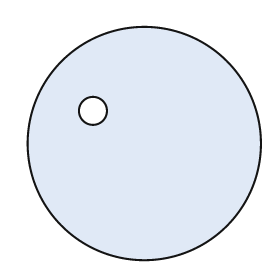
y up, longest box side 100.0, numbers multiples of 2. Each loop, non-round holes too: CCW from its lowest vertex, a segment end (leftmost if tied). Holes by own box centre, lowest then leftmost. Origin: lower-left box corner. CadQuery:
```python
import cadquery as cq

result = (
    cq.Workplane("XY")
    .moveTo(50.0, 50.0)
    .circle(50.0)
    .moveTo(28.0, 64.0)
    .circle(6.0)
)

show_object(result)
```